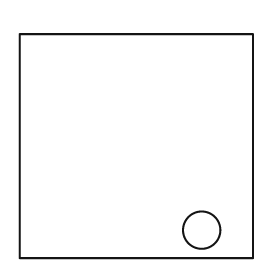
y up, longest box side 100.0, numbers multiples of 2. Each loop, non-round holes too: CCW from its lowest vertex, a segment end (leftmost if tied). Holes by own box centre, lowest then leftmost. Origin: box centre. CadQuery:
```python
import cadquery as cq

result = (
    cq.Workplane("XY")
    .moveTo(-50.0, -48.0)
    .lineTo(50.0, -48.0)
    .lineTo(50.0, 48.0)
    .lineTo(-50.0, 48.0)
    .close()
    .moveTo(28.0, -36.0)
    .circle(8.0)
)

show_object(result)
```